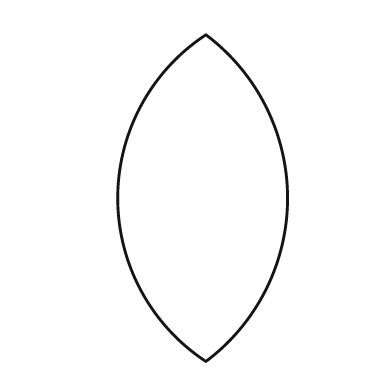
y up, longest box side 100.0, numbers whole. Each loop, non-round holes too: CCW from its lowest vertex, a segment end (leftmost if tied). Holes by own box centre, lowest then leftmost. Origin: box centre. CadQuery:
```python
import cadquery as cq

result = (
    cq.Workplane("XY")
    .moveTo(1.0, -50.0)
    .threePointArc((26.0, 0.0), (1.0, 50.0))
    .threePointArc((-26.0, 0.0), (1.0, -50.0))
    .close()
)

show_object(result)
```